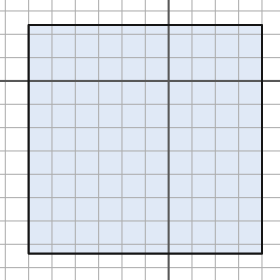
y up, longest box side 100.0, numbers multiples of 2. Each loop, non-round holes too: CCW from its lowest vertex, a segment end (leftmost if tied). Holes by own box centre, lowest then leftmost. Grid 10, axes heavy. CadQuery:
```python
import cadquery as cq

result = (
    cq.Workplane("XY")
    .moveTo(-60.0, -74.0)
    .lineTo(40.0, -74.0)
    .lineTo(40.0, 24.0)
    .lineTo(-60.0, 24.0)
    .close()
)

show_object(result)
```